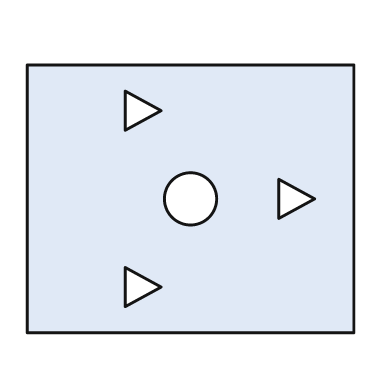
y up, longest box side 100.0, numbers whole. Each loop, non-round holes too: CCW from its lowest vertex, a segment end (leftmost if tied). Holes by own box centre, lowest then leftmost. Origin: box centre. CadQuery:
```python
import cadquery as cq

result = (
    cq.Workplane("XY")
    .moveTo(-50.0, -41.0)
    .lineTo(50.0, -41.0)
    .lineTo(50.0, 41.0)
    .lineTo(-50.0, 41.0)
    .close()
    .moveTo(-20.0, -33.0)
    .lineTo(-9.0, -27.0)
    .lineTo(-20.0, -21.0)
    .close()
    .moveTo(0.0, 0.0)
    .circle(8.0)
    .moveTo(27.0, -6.0)
    .lineTo(38.0, 0.0)
    .lineTo(27.0, 6.0)
    .close()
    .moveTo(-20.0, 21.0)
    .lineTo(-9.0, 27.0)
    .lineTo(-20.0, 33.0)
    .close()
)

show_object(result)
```